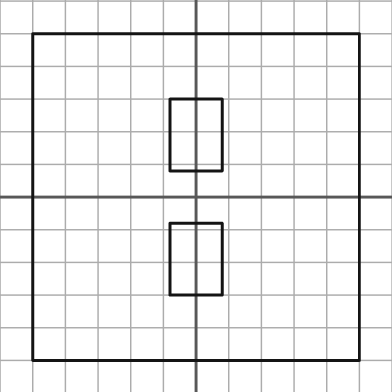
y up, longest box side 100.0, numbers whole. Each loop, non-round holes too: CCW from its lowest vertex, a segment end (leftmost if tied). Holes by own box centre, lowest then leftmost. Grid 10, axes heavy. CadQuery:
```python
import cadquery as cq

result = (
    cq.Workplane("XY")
    .moveTo(-50.0, -50.0)
    .lineTo(50.0, -50.0)
    .lineTo(50.0, 50.0)
    .lineTo(-50.0, 50.0)
    .close()
    .moveTo(-8.0, -30.0)
    .lineTo(8.0, -30.0)
    .lineTo(8.0, -8.0)
    .lineTo(-8.0, -8.0)
    .close()
    .moveTo(-8.0, 8.0)
    .lineTo(8.0, 8.0)
    .lineTo(8.0, 30.0)
    .lineTo(-8.0, 30.0)
    .close()
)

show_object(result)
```